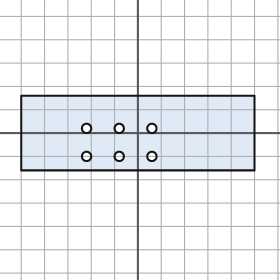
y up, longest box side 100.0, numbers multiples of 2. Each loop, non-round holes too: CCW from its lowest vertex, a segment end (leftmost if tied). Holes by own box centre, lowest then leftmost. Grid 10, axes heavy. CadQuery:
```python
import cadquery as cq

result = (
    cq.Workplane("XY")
    .moveTo(-50.0, -16.0)
    .lineTo(50.0, -16.0)
    .lineTo(50.0, 16.0)
    .lineTo(-50.0, 16.0)
    .close()
    .moveTo(-22.0, -10.0)
    .circle(2.0)
    .moveTo(-8.0, -10.0)
    .circle(2.0)
    .moveTo(6.0, -10.0)
    .circle(2.0)
    .moveTo(-22.0, 2.0)
    .circle(2.0)
    .moveTo(-8.0, 2.0)
    .circle(2.0)
    .moveTo(6.0, 2.0)
    .circle(2.0)
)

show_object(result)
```